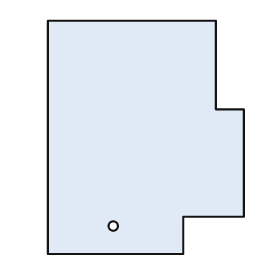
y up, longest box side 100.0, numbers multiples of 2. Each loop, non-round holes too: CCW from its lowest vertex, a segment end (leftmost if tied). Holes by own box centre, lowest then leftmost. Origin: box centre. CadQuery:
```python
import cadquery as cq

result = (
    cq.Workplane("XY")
    .moveTo(-42.0, -50.0)
    .lineTo(16.0, -50.0)
    .lineTo(16.0, -34.0)
    .lineTo(42.0, -34.0)
    .lineTo(42.0, 12.0)
    .lineTo(30.0, 12.0)
    .lineTo(30.0, 50.0)
    .lineTo(-42.0, 50.0)
    .close()
    .moveTo(-14.0, -38.0)
    .circle(2.0)
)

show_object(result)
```